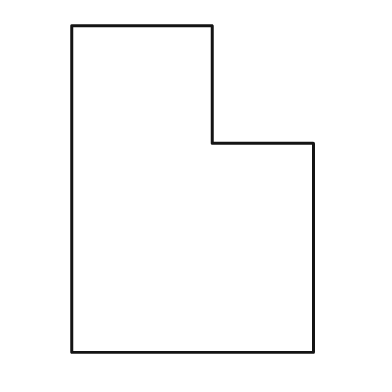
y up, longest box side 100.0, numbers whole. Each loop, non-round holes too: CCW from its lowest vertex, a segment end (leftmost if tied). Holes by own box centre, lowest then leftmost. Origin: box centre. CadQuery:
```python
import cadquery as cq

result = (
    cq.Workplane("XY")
    .moveTo(-37.0, -50.0)
    .lineTo(37.0, -50.0)
    .lineTo(37.0, 14.0)
    .lineTo(6.0, 14.0)
    .lineTo(6.0, 50.0)
    .lineTo(-37.0, 50.0)
    .close()
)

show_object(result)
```